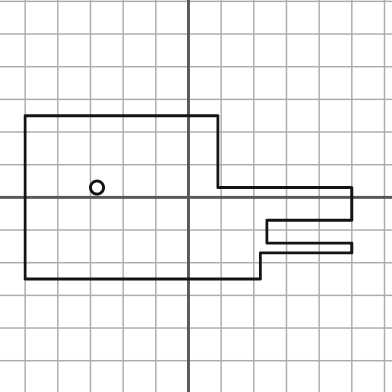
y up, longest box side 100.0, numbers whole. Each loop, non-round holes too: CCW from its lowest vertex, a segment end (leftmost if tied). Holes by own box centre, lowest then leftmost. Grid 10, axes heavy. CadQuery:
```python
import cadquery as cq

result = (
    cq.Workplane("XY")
    .moveTo(-50.0, -25.0)
    .lineTo(22.0, -25.0)
    .lineTo(22.0, -17.0)
    .lineTo(50.0, -17.0)
    .lineTo(50.0, -14.0)
    .lineTo(24.0, -14.0)
    .lineTo(24.0, -7.0)
    .lineTo(50.0, -7.0)
    .lineTo(50.0, 3.0)
    .lineTo(9.0, 3.0)
    .lineTo(9.0, 25.0)
    .lineTo(-50.0, 25.0)
    .close()
    .moveTo(-28.0, 3.0)
    .circle(2.0)
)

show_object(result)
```